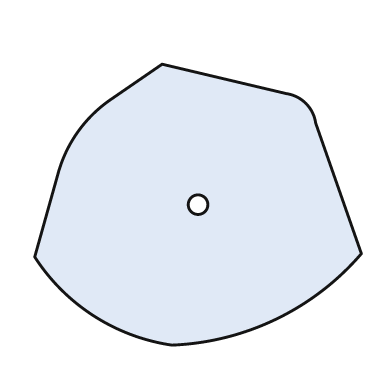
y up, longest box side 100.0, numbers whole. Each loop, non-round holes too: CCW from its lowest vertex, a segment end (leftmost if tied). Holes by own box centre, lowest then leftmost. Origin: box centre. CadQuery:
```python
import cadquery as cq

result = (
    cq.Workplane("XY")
    .moveTo(-8.0, -43.0)
    .threePointArc((24.0, -35.0), (50.0, -15.0))
    .lineTo(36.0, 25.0)
    .threePointArc((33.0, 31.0), (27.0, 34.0))
    .lineTo(-11.0, 43.0)
    .lineTo(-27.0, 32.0)
    .threePointArc((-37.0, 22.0), (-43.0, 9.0))
    .lineTo(-50.0, -16.0)
    .threePointArc((-32.0, -34.0), (-8.0, -43.0))
    .close()
    .moveTo(0.0, 0.0)
    .circle(3.0)
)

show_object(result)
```